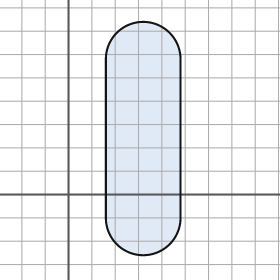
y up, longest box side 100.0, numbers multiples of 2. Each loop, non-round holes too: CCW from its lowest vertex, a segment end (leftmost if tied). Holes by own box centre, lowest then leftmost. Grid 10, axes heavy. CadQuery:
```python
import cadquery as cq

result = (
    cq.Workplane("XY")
    .moveTo(16.0, -10.0)
    .threePointArc((32.0, -26.0), (48.0, -10.0))
    .lineTo(48.0, 58.0)
    .threePointArc((32.0, 74.0), (16.0, 58.0))
    .close()
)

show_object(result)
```